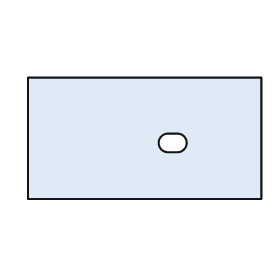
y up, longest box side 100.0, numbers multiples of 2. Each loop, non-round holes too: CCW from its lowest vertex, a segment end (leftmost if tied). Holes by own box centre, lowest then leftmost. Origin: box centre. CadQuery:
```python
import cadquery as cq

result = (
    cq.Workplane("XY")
    .moveTo(-50.0, -26.0)
    .lineTo(50.0, -26.0)
    .lineTo(50.0, 26.0)
    .lineTo(-50.0, 26.0)
    .close()
    .moveTo(10.0, -6.0)
    .lineTo(14.0, -6.0)
    .threePointArc((18.0, -2.0), (14.0, 2.0))
    .lineTo(10.0, 2.0)
    .threePointArc((6.0, -2.0), (10.0, -6.0))
    .close()
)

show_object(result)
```